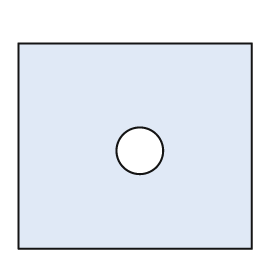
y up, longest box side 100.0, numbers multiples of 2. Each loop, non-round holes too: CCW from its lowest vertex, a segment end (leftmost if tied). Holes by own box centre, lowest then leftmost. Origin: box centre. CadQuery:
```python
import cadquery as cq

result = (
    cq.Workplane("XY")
    .moveTo(-50.0, -44.0)
    .lineTo(50.0, -44.0)
    .lineTo(50.0, 44.0)
    .lineTo(-50.0, 44.0)
    .close()
    .moveTo(2.0, -2.0)
    .circle(10.0)
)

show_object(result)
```